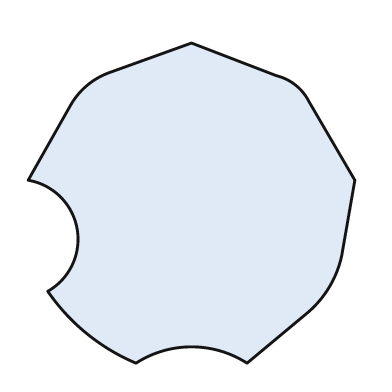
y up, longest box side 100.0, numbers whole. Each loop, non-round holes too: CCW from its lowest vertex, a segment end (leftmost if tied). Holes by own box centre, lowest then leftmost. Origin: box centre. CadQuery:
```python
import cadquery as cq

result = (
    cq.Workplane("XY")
    .moveTo(-17.0, -49.0)
    .threePointArc((0.0, -44.0), (17.0, -49.0))
    .lineTo(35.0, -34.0)
    .threePointArc((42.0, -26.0), (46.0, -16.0))
    .lineTo(50.0, 7.0)
    .lineTo(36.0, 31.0)
    .threePointArc((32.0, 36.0), (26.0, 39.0))
    .lineTo(0.0, 49.0)
    .lineTo(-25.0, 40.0)
    .threePointArc((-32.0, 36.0), (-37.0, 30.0))
    .lineTo(-50.0, 7.0)
    .threePointArc((-35.0, -8.0), (-44.0, -27.0))
    .threePointArc((-32.0, -40.0), (-17.0, -49.0))
    .close()
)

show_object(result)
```